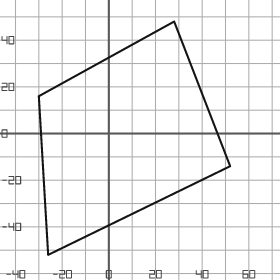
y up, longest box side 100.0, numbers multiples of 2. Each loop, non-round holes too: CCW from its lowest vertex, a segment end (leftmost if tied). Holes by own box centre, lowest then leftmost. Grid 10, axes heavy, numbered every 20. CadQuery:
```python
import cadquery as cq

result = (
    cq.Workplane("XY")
    .moveTo(-26.0, -52.0)
    .lineTo(52.0, -14.0)
    .lineTo(28.0, 48.0)
    .lineTo(-30.0, 16.0)
    .close()
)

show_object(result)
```